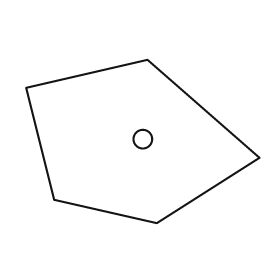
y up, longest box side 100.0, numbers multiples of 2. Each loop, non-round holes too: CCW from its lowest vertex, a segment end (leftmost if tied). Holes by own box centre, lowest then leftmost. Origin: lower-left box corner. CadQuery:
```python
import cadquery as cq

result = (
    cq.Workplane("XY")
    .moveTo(56.0, 0.0)
    .lineTo(100.0, 28.0)
    .lineTo(52.0, 70.0)
    .lineTo(0.0, 58.0)
    .lineTo(12.0, 10.0)
    .close()
    .moveTo(50.0, 36.0)
    .circle(4.0)
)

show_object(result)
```